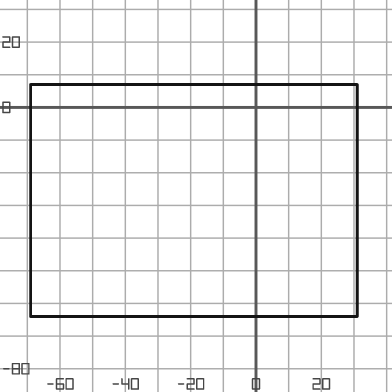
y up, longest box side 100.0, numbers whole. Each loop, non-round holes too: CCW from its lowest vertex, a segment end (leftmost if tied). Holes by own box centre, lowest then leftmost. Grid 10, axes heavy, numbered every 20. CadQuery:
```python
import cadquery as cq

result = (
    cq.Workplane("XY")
    .moveTo(-69.0, -64.0)
    .lineTo(31.0, -64.0)
    .lineTo(31.0, 7.0)
    .lineTo(-69.0, 7.0)
    .close()
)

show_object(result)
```